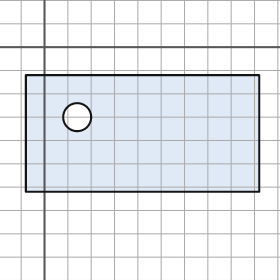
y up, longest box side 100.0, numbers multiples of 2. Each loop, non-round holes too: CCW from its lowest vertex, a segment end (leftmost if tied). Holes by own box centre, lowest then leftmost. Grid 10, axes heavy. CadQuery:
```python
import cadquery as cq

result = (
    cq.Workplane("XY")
    .moveTo(-8.0, -62.0)
    .lineTo(92.0, -62.0)
    .lineTo(92.0, -12.0)
    .lineTo(-8.0, -12.0)
    .close()
    .moveTo(14.0, -30.0)
    .circle(6.0)
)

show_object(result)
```